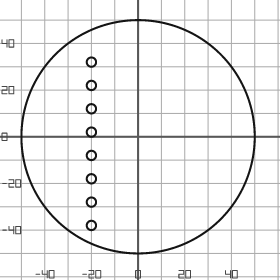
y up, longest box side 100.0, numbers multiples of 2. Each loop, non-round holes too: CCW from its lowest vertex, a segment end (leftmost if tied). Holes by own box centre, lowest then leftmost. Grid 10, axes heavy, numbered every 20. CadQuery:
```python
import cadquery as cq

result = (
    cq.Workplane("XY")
    .moveTo(0.0, 0.0)
    .circle(50.0)
    .moveTo(-20.0, -38.0)
    .circle(2.0)
    .moveTo(-20.0, -28.0)
    .circle(2.0)
    .moveTo(-20.0, -18.0)
    .circle(2.0)
    .moveTo(-20.0, -8.0)
    .circle(2.0)
    .moveTo(-20.0, 2.0)
    .circle(2.0)
    .moveTo(-20.0, 12.0)
    .circle(2.0)
    .moveTo(-20.0, 22.0)
    .circle(2.0)
    .moveTo(-20.0, 32.0)
    .circle(2.0)
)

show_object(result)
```